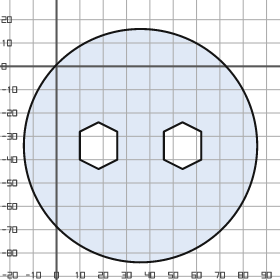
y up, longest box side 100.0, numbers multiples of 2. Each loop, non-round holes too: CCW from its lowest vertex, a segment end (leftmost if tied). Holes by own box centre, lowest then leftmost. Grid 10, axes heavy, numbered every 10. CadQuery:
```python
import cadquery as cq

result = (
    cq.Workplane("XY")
    .moveTo(36.0, -34.0)
    .circle(50.0)
    .moveTo(18.0, -44.0)
    .lineTo(26.0, -40.0)
    .lineTo(26.0, -28.0)
    .lineTo(18.0, -24.0)
    .lineTo(10.0, -28.0)
    .lineTo(10.0, -40.0)
    .close()
    .moveTo(54.0, -44.0)
    .lineTo(62.0, -40.0)
    .lineTo(62.0, -28.0)
    .lineTo(54.0, -24.0)
    .lineTo(46.0, -28.0)
    .lineTo(46.0, -40.0)
    .close()
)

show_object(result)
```